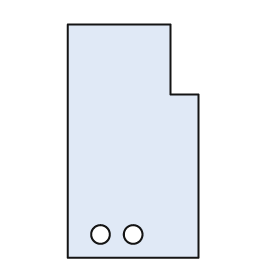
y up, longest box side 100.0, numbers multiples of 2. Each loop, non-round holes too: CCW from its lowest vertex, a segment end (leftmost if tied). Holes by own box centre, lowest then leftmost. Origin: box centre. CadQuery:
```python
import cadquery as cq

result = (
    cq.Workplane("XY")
    .moveTo(-28.0, -50.0)
    .lineTo(28.0, -50.0)
    .lineTo(28.0, 20.0)
    .lineTo(16.0, 20.0)
    .lineTo(16.0, 50.0)
    .lineTo(-28.0, 50.0)
    .close()
    .moveTo(-14.0, -40.0)
    .circle(4.0)
    .moveTo(0.0, -40.0)
    .circle(4.0)
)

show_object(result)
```